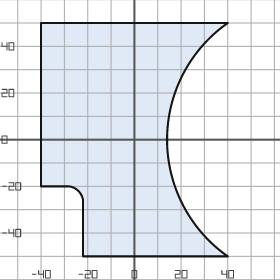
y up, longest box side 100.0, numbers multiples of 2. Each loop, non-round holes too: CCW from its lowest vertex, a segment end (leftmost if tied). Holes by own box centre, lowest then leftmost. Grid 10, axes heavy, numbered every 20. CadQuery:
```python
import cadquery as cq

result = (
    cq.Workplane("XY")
    .moveTo(-22.0, -50.0)
    .lineTo(40.0, -50.0)
    .threePointArc((14.0, 0.0), (40.0, 50.0))
    .lineTo(-40.0, 50.0)
    .lineTo(-40.0, -20.0)
    .lineTo(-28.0, -20.0)
    .threePointArc((-24.0, -22.0), (-22.0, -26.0))
    .close()
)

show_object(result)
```